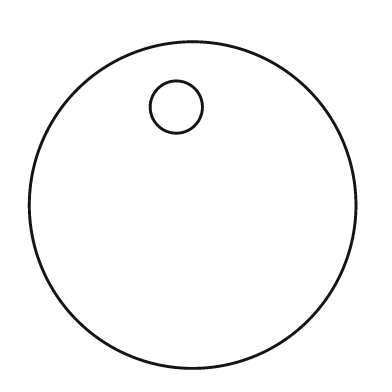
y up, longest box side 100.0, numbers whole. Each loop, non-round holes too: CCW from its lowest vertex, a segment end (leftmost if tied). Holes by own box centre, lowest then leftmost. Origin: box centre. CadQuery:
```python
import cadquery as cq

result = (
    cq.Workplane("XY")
    .moveTo(0.0, 0.0)
    .circle(50.0)
    .moveTo(-5.0, 30.0)
    .circle(8.0)
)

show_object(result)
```